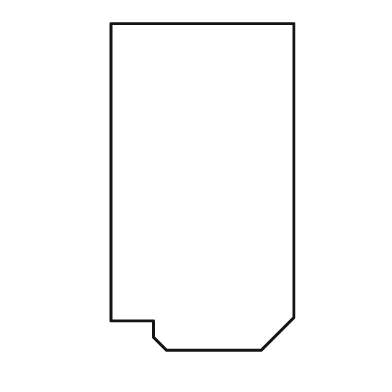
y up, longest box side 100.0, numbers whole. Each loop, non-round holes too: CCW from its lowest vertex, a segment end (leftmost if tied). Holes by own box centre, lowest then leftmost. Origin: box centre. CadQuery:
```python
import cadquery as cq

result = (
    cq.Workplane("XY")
    .moveTo(-11.0, -50.0)
    .lineTo(18.0, -50.0)
    .lineTo(28.0, -40.0)
    .lineTo(28.0, 50.0)
    .lineTo(-28.0, 50.0)
    .lineTo(-28.0, -41.0)
    .lineTo(-15.0, -41.0)
    .lineTo(-15.0, -46.0)
    .close()
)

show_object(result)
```